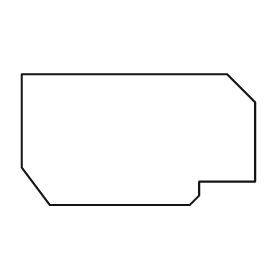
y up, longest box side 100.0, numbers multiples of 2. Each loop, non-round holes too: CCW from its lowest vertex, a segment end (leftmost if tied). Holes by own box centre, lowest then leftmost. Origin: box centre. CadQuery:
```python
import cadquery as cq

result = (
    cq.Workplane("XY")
    .moveTo(-38.0, -28.0)
    .lineTo(22.0, -28.0)
    .lineTo(26.0, -24.0)
    .lineTo(26.0, -18.0)
    .lineTo(50.0, -18.0)
    .lineTo(50.0, 16.0)
    .lineTo(38.0, 28.0)
    .lineTo(-50.0, 28.0)
    .lineTo(-50.0, -12.0)
    .close()
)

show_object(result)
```